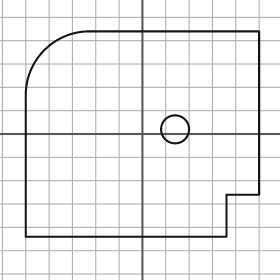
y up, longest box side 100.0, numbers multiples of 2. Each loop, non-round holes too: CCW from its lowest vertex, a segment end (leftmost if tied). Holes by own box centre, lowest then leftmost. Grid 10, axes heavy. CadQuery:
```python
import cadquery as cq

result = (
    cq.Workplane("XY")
    .moveTo(-50.0, -44.0)
    .lineTo(36.0, -44.0)
    .lineTo(36.0, -26.0)
    .lineTo(50.0, -26.0)
    .lineTo(50.0, 44.0)
    .lineTo(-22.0, 44.0)
    .threePointArc((-42.0, 36.0), (-50.0, 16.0))
    .close()
    .moveTo(14.0, 2.0)
    .circle(6.0)
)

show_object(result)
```